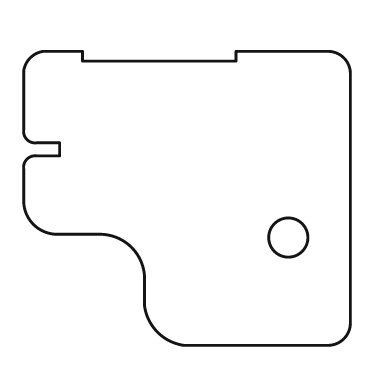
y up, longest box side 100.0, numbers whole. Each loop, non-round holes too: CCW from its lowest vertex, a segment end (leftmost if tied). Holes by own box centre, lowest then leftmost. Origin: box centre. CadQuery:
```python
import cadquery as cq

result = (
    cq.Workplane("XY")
    .moveTo(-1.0, -45.0)
    .lineTo(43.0, -45.0)
    .threePointArc((48.0, -43.0), (50.0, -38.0))
    .lineTo(50.0, 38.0)
    .threePointArc((48.0, 43.0), (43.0, 45.0))
    .lineTo(15.0, 45.0)
    .lineTo(15.0, 42.0)
    .lineTo(-32.0, 42.0)
    .lineTo(-32.0, 45.0)
    .lineTo(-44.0, 45.0)
    .threePointArc((-48.0, 43.0), (-50.0, 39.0))
    .lineTo(-50.0, 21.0)
    .threePointArc((-49.0, 18.0), (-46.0, 17.0))
    .lineTo(-39.0, 17.0)
    .lineTo(-39.0, 13.0)
    .lineTo(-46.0, 13.0)
    .threePointArc((-49.0, 12.0), (-50.0, 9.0))
    .lineTo(-50.0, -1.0)
    .threePointArc((-47.0, -8.0), (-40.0, -11.0))
    .lineTo(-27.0, -11.0)
    .threePointArc((-17.0, -15.0), (-13.0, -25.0))
    .lineTo(-13.0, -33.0)
    .threePointArc((-9.0, -41.0), (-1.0, -45.0))
    .close()
    .moveTo(31.0, -12.0)
    .circle(6.0)
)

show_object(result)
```